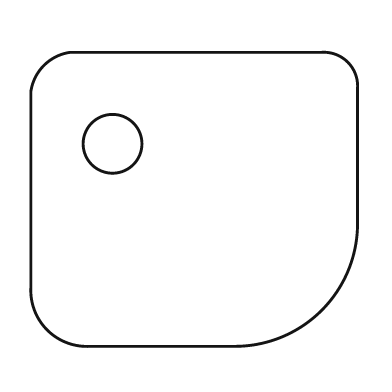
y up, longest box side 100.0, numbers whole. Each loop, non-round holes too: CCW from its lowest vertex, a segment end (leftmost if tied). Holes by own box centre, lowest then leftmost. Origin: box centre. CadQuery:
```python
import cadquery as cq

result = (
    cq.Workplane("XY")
    .moveTo(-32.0, -45.0)
    .lineTo(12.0, -45.0)
    .threePointArc((39.0, -34.0), (50.0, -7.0))
    .lineTo(50.0, 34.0)
    .threePointArc((47.0, 42.0), (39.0, 45.0))
    .lineTo(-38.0, 45.0)
    .threePointArc((-46.0, 41.0), (-50.0, 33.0))
    .lineTo(-50.0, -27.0)
    .threePointArc((-45.0, -40.0), (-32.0, -45.0))
    .close()
    .moveTo(-25.0, 17.0)
    .circle(9.0)
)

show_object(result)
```